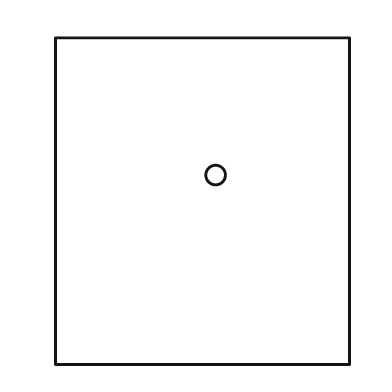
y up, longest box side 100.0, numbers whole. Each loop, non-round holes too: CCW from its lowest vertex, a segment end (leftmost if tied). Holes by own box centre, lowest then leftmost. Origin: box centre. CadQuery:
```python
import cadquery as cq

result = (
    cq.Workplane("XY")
    .moveTo(-45.0, -50.0)
    .lineTo(45.0, -50.0)
    .lineTo(45.0, 50.0)
    .lineTo(-45.0, 50.0)
    .close()
    .moveTo(4.0, 8.0)
    .circle(3.0)
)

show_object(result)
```